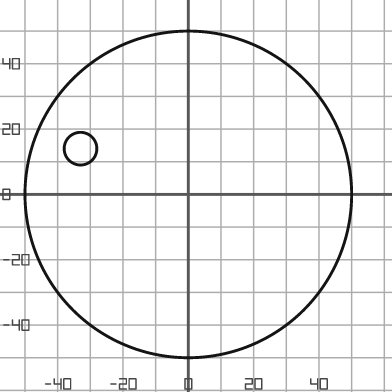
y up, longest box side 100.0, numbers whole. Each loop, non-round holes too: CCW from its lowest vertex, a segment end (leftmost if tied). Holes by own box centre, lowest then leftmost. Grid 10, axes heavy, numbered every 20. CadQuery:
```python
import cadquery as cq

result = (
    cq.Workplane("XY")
    .moveTo(0.0, 0.0)
    .circle(50.0)
    .moveTo(-33.0, 14.0)
    .circle(5.0)
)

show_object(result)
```